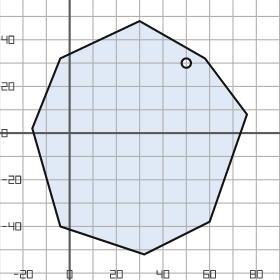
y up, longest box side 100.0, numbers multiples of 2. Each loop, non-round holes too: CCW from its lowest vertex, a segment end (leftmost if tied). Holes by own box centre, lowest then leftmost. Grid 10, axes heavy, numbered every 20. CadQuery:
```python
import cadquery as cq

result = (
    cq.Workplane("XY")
    .moveTo(32.0, -52.0)
    .lineTo(60.0, -38.0)
    .lineTo(76.0, 8.0)
    .lineTo(58.0, 32.0)
    .lineTo(30.0, 48.0)
    .lineTo(-4.0, 32.0)
    .lineTo(-16.0, 2.0)
    .lineTo(-4.0, -40.0)
    .close()
    .moveTo(50.0, 30.0)
    .circle(2.0)
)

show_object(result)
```